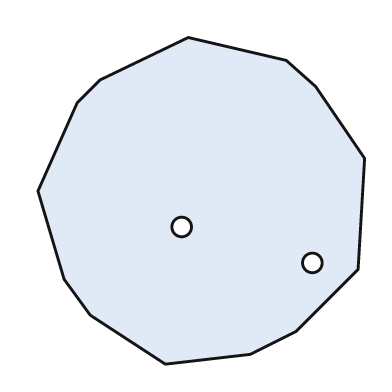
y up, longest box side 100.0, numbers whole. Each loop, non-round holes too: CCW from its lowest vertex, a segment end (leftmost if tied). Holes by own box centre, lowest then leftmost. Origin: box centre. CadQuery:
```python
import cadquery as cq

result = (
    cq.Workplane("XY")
    .moveTo(-11.0, -50.0)
    .lineTo(15.0, -47.0)
    .lineTo(29.0, -40.0)
    .lineTo(48.0, -21.0)
    .lineTo(50.0, 13.0)
    .lineTo(35.0, 35.0)
    .lineTo(26.0, 43.0)
    .lineTo(-4.0, 50.0)
    .lineTo(-31.0, 37.0)
    .lineTo(-38.0, 30.0)
    .lineTo(-50.0, 3.0)
    .lineTo(-42.0, -24.0)
    .lineTo(-34.0, -35.0)
    .close()
    .moveTo(34.0, -19.0)
    .circle(3.0)
    .moveTo(-6.0, -8.0)
    .circle(3.0)
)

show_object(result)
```